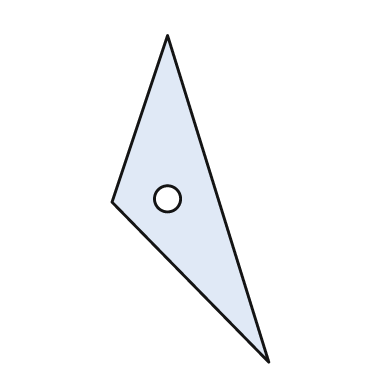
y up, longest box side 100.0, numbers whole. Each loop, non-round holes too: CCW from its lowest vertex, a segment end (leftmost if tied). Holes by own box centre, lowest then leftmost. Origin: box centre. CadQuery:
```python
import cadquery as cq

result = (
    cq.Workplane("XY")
    .moveTo(24.0, -50.0)
    .lineTo(-7.0, 50.0)
    .lineTo(-24.0, -1.0)
    .close()
    .moveTo(-7.0, 0.0)
    .circle(4.0)
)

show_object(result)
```